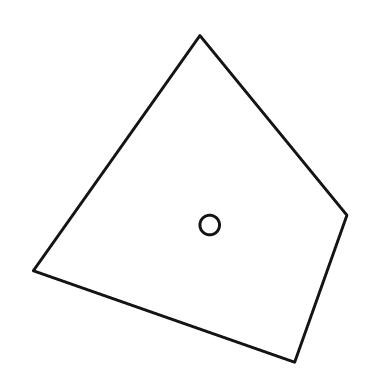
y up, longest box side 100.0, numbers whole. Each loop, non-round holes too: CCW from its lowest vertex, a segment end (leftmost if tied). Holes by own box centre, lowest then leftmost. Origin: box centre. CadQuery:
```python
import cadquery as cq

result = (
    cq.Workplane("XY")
    .moveTo(32.0, -50.0)
    .lineTo(48.0, -5.0)
    .lineTo(3.0, 50.0)
    .lineTo(-48.0, -22.0)
    .close()
    .moveTo(6.0, -8.0)
    .circle(3.0)
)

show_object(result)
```